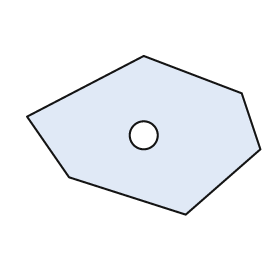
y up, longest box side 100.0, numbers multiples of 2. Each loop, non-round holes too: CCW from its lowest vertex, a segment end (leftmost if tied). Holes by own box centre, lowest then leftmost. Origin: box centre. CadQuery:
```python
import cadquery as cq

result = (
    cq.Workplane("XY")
    .moveTo(18.0, -34.0)
    .lineTo(50.0, -6.0)
    .lineTo(42.0, 18.0)
    .lineTo(0.0, 34.0)
    .lineTo(-50.0, 8.0)
    .lineTo(-32.0, -18.0)
    .close()
    .moveTo(0.0, 0.0)
    .circle(6.0)
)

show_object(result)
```